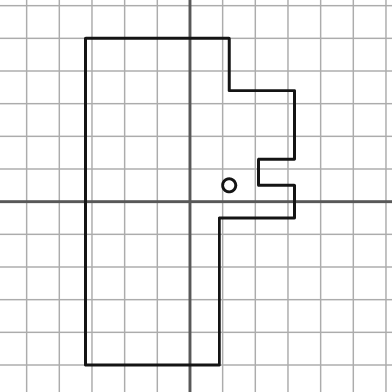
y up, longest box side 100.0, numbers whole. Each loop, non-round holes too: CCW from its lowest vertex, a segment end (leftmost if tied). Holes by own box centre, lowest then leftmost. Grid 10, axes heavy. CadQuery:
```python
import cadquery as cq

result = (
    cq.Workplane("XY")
    .moveTo(-32.0, -50.0)
    .lineTo(9.0, -50.0)
    .lineTo(9.0, -5.0)
    .lineTo(32.0, -5.0)
    .lineTo(32.0, 5.0)
    .lineTo(21.0, 5.0)
    .lineTo(21.0, 13.0)
    .lineTo(32.0, 13.0)
    .lineTo(32.0, 34.0)
    .lineTo(12.0, 34.0)
    .lineTo(12.0, 50.0)
    .lineTo(-32.0, 50.0)
    .close()
    .moveTo(12.0, 5.0)
    .circle(2.0)
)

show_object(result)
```